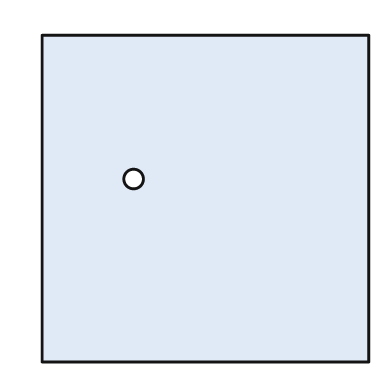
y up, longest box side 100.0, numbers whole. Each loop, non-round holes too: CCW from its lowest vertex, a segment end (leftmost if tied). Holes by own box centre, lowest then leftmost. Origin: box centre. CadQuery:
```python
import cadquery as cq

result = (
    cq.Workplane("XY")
    .moveTo(-50.0, -50.0)
    .lineTo(50.0, -50.0)
    .lineTo(50.0, 50.0)
    .lineTo(-50.0, 50.0)
    .close()
    .moveTo(-22.0, 6.0)
    .circle(3.0)
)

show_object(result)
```